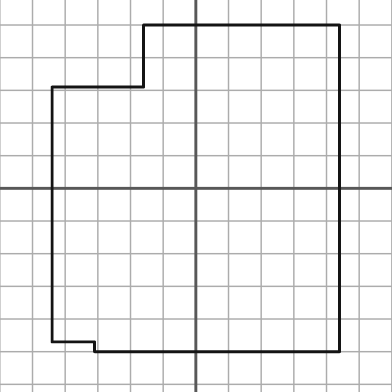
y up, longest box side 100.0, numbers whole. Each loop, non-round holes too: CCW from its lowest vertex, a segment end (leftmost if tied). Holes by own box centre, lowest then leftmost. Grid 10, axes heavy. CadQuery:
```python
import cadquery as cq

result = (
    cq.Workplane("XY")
    .moveTo(-31.0, -50.0)
    .lineTo(44.0, -50.0)
    .lineTo(44.0, 50.0)
    .lineTo(-16.0, 50.0)
    .lineTo(-16.0, 31.0)
    .lineTo(-44.0, 31.0)
    .lineTo(-44.0, -47.0)
    .lineTo(-31.0, -47.0)
    .close()
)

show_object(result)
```